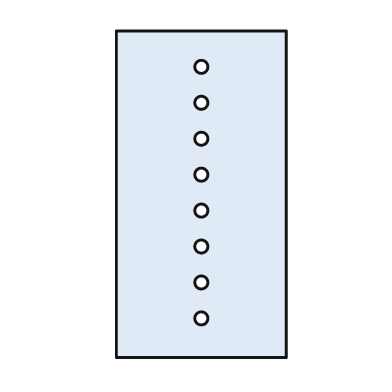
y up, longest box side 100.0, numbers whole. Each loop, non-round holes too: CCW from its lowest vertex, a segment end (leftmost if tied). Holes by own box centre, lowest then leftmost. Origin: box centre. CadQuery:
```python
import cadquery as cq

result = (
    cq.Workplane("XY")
    .moveTo(-26.0, -50.0)
    .lineTo(26.0, -50.0)
    .lineTo(26.0, 50.0)
    .lineTo(-26.0, 50.0)
    .close()
    .moveTo(0.0, -38.0)
    .circle(2.0)
    .moveTo(0.0, -27.0)
    .circle(2.0)
    .moveTo(0.0, -16.0)
    .circle(2.0)
    .moveTo(0.0, -5.0)
    .circle(2.0)
    .moveTo(0.0, 6.0)
    .circle(2.0)
    .moveTo(0.0, 17.0)
    .circle(2.0)
    .moveTo(0.0, 28.0)
    .circle(2.0)
    .moveTo(0.0, 39.0)
    .circle(2.0)
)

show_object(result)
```